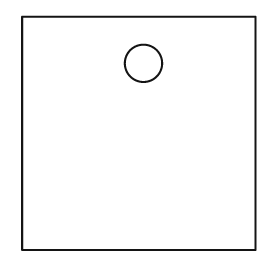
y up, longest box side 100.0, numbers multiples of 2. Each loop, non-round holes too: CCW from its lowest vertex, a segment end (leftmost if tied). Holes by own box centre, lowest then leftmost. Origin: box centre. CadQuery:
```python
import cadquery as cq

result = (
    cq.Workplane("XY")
    .moveTo(-50.0, -50.0)
    .lineTo(50.0, -50.0)
    .lineTo(50.0, 50.0)
    .lineTo(-50.0, 50.0)
    .close()
    .moveTo(2.0, 30.0)
    .circle(8.0)
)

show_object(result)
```